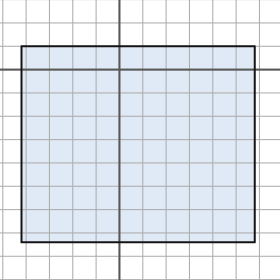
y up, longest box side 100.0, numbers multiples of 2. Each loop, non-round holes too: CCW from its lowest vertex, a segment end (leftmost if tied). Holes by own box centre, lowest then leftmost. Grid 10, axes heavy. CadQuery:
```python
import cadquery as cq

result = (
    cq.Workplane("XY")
    .moveTo(-42.0, -74.0)
    .lineTo(58.0, -74.0)
    .lineTo(58.0, 10.0)
    .lineTo(-42.0, 10.0)
    .close()
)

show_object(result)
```